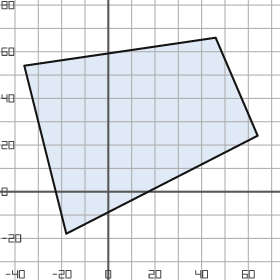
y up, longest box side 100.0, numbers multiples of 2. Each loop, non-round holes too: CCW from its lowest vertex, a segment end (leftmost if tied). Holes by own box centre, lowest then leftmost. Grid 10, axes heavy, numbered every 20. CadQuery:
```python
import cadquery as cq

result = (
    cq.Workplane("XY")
    .moveTo(-18.0, -18.0)
    .lineTo(64.0, 24.0)
    .lineTo(46.0, 66.0)
    .lineTo(-36.0, 54.0)
    .close()
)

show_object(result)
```